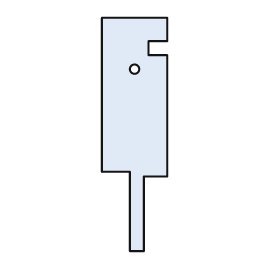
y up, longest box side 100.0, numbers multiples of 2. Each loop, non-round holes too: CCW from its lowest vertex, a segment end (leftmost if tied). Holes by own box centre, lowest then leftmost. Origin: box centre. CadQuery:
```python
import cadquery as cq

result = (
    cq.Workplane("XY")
    .moveTo(-2.0, -50.0)
    .lineTo(4.0, -50.0)
    .lineTo(4.0, -18.0)
    .lineTo(14.0, -18.0)
    .lineTo(14.0, 34.0)
    .lineTo(6.0, 34.0)
    .lineTo(6.0, 40.0)
    .lineTo(14.0, 40.0)
    .lineTo(14.0, 50.0)
    .lineTo(-14.0, 50.0)
    .lineTo(-14.0, -16.0)
    .lineTo(-2.0, -16.0)
    .close()
    .moveTo(0.0, 28.0)
    .circle(2.0)
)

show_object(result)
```